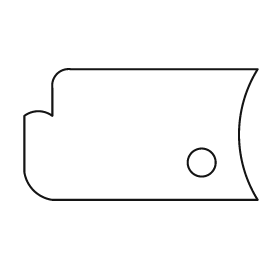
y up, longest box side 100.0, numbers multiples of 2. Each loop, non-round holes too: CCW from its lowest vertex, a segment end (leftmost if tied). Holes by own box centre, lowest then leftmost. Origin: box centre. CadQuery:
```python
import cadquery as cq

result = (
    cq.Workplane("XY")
    .moveTo(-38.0, -28.0)
    .lineTo(50.0, -28.0)
    .threePointArc((42.0, 0.0), (50.0, 28.0))
    .lineTo(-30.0, 28.0)
    .threePointArc((-36.0, 26.0), (-38.0, 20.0))
    .lineTo(-38.0, 8.0)
    .threePointArc((-44.0, 10.0), (-50.0, 8.0))
    .lineTo(-50.0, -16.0)
    .threePointArc((-46.0, -24.0), (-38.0, -28.0))
    .close()
    .moveTo(26.0, -12.0)
    .circle(6.0)
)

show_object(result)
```